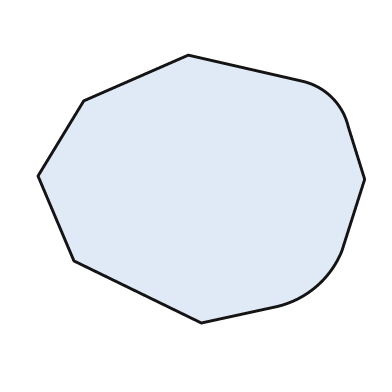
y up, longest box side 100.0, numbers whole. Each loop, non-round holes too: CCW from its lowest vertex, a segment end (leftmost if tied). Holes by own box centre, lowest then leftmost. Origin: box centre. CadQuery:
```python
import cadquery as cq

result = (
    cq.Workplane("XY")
    .moveTo(0.0, -41.0)
    .lineTo(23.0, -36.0)
    .threePointArc((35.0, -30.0), (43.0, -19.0))
    .lineTo(50.0, 3.0)
    .lineTo(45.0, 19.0)
    .threePointArc((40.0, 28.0), (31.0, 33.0))
    .lineTo(-4.0, 41.0)
    .lineTo(-36.0, 27.0)
    .lineTo(-50.0, 4.0)
    .lineTo(-39.0, -22.0)
    .close()
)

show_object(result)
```